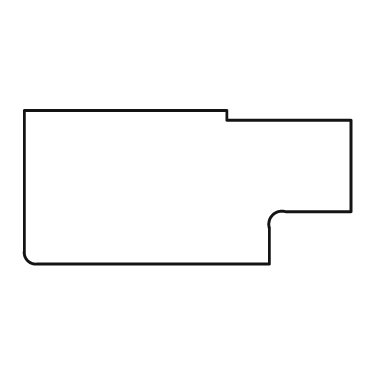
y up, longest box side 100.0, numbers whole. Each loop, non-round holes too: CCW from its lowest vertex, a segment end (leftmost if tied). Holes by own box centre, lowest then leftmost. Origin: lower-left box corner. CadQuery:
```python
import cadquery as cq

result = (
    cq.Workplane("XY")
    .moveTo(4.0, 0.0)
    .lineTo(75.0, 0.0)
    .lineTo(75.0, 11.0)
    .threePointArc((76.0, 15.0), (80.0, 16.0))
    .lineTo(100.0, 16.0)
    .lineTo(100.0, 44.0)
    .lineTo(62.0, 44.0)
    .lineTo(62.0, 47.0)
    .lineTo(0.0, 47.0)
    .lineTo(0.0, 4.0)
    .threePointArc((1.0, 1.0), (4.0, 0.0))
    .close()
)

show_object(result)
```